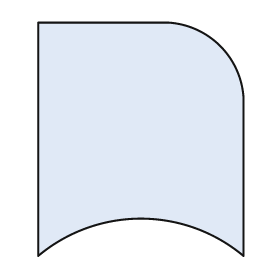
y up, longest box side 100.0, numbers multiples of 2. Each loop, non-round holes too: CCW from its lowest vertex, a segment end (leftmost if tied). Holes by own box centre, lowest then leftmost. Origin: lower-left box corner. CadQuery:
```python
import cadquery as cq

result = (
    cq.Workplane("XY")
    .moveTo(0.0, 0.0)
    .threePointArc((44.0, 16.0), (88.0, 0.0))
    .lineTo(88.0, 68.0)
    .threePointArc((78.0, 90.0), (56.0, 100.0))
    .lineTo(0.0, 100.0)
    .close()
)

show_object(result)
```